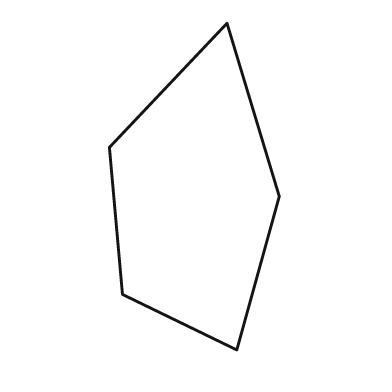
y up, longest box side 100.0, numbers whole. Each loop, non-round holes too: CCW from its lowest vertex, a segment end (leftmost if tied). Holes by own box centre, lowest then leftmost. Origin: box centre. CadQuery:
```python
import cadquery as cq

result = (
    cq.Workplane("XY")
    .moveTo(13.0, -50.0)
    .lineTo(26.0, -3.0)
    .lineTo(10.0, 50.0)
    .lineTo(-26.0, 12.0)
    .lineTo(-22.0, -33.0)
    .close()
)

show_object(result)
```